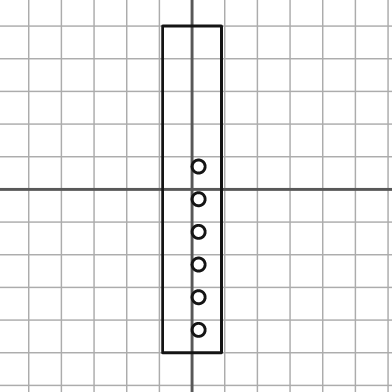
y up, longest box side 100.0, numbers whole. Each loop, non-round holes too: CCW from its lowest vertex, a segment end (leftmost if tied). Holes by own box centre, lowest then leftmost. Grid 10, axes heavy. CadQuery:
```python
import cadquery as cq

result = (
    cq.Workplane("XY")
    .moveTo(-9.0, -50.0)
    .lineTo(9.0, -50.0)
    .lineTo(9.0, 50.0)
    .lineTo(-9.0, 50.0)
    .close()
    .moveTo(2.0, -43.0)
    .circle(2.0)
    .moveTo(2.0, -33.0)
    .circle(2.0)
    .moveTo(2.0, -23.0)
    .circle(2.0)
    .moveTo(2.0, -13.0)
    .circle(2.0)
    .moveTo(2.0, -3.0)
    .circle(2.0)
    .moveTo(2.0, 7.0)
    .circle(2.0)
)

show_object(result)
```